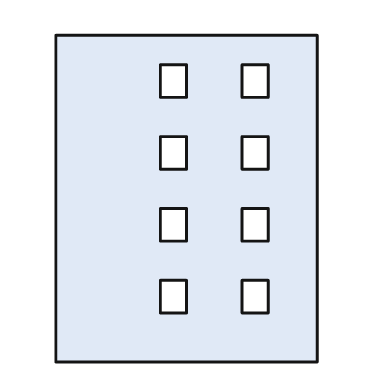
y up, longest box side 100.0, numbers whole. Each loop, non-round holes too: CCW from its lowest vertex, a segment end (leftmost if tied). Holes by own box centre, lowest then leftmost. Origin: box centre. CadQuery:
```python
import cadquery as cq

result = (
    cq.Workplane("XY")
    .moveTo(-40.0, -50.0)
    .lineTo(40.0, -50.0)
    .lineTo(40.0, 50.0)
    .lineTo(-40.0, 50.0)
    .close()
    .moveTo(-8.0, -35.0)
    .lineTo(0.0, -35.0)
    .lineTo(0.0, -25.0)
    .lineTo(-8.0, -25.0)
    .close()
    .moveTo(17.0, -35.0)
    .lineTo(25.0, -35.0)
    .lineTo(25.0, -25.0)
    .lineTo(17.0, -25.0)
    .close()
    .moveTo(-8.0, -13.0)
    .lineTo(0.0, -13.0)
    .lineTo(0.0, -3.0)
    .lineTo(-8.0, -3.0)
    .close()
    .moveTo(17.0, -13.0)
    .lineTo(25.0, -13.0)
    .lineTo(25.0, -3.0)
    .lineTo(17.0, -3.0)
    .close()
    .moveTo(-8.0, 9.0)
    .lineTo(0.0, 9.0)
    .lineTo(0.0, 19.0)
    .lineTo(-8.0, 19.0)
    .close()
    .moveTo(17.0, 9.0)
    .lineTo(25.0, 9.0)
    .lineTo(25.0, 19.0)
    .lineTo(17.0, 19.0)
    .close()
    .moveTo(-8.0, 31.0)
    .lineTo(0.0, 31.0)
    .lineTo(0.0, 41.0)
    .lineTo(-8.0, 41.0)
    .close()
    .moveTo(17.0, 31.0)
    .lineTo(25.0, 31.0)
    .lineTo(25.0, 41.0)
    .lineTo(17.0, 41.0)
    .close()
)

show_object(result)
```